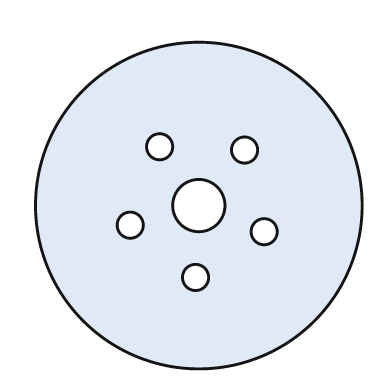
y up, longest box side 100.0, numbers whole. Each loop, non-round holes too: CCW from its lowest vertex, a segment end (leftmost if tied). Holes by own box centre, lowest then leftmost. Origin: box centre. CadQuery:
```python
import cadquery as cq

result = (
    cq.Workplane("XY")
    .moveTo(0.0, 0.0)
    .circle(50.0)
    .moveTo(-1.0, -22.0)
    .circle(4.0)
    .moveTo(20.0, -8.0)
    .circle(4.0)
    .moveTo(-21.0, -6.0)
    .circle(4.0)
    .moveTo(0.0, 0.0)
    .circle(8.0)
    .moveTo(14.0, 17.0)
    .circle(4.0)
    .moveTo(-12.0, 18.0)
    .circle(4.0)
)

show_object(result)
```